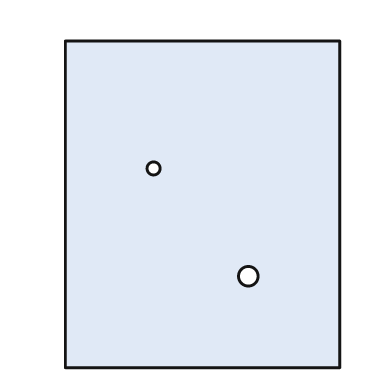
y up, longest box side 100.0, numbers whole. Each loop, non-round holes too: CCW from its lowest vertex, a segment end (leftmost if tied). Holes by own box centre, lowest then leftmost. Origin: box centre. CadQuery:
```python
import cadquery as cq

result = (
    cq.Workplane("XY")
    .moveTo(-42.0, -50.0)
    .lineTo(42.0, -50.0)
    .lineTo(42.0, 50.0)
    .lineTo(-42.0, 50.0)
    .close()
    .moveTo(14.0, -22.0)
    .circle(3.0)
    .moveTo(-15.0, 11.0)
    .circle(2.0)
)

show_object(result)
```